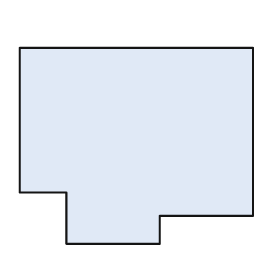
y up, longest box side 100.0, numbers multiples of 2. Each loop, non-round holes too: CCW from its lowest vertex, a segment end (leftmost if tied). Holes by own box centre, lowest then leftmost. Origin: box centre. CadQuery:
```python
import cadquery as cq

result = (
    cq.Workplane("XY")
    .moveTo(-30.0, -42.0)
    .lineTo(10.0, -42.0)
    .lineTo(10.0, -30.0)
    .lineTo(50.0, -30.0)
    .lineTo(50.0, 42.0)
    .lineTo(-50.0, 42.0)
    .lineTo(-50.0, -20.0)
    .lineTo(-30.0, -20.0)
    .close()
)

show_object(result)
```